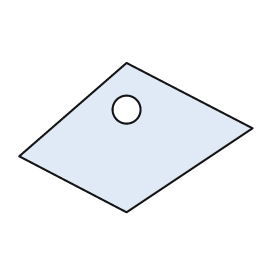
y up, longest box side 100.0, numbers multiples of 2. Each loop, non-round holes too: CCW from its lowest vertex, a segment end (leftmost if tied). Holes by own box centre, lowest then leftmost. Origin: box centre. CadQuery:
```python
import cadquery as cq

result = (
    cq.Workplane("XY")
    .moveTo(-4.0, -32.0)
    .lineTo(50.0, 4.0)
    .lineTo(-4.0, 32.0)
    .lineTo(-50.0, -8.0)
    .close()
    .moveTo(-4.0, 12.0)
    .circle(6.0)
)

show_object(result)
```